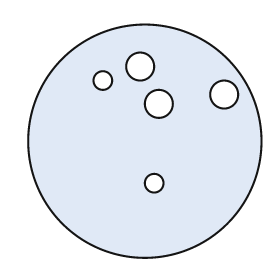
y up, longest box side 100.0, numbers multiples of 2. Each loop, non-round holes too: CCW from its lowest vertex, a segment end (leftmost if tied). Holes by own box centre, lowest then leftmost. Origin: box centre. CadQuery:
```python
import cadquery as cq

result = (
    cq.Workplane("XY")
    .moveTo(0.0, 0.0)
    .circle(50.0)
    .moveTo(4.0, -18.0)
    .circle(4.0)
    .moveTo(6.0, 16.0)
    .circle(6.0)
    .moveTo(34.0, 20.0)
    .circle(6.0)
    .moveTo(-18.0, 26.0)
    .circle(4.0)
    .moveTo(-2.0, 32.0)
    .circle(6.0)
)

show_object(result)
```